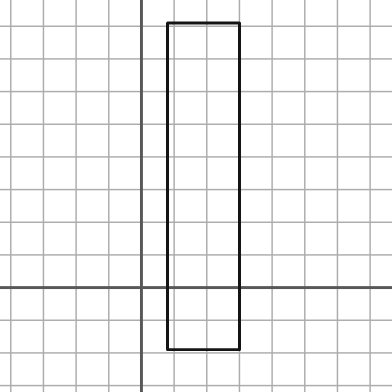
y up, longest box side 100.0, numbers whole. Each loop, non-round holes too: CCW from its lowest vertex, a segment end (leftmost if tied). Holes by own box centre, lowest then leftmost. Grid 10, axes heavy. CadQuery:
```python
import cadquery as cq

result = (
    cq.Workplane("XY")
    .moveTo(8.0, -19.0)
    .lineTo(30.0, -19.0)
    .lineTo(30.0, 81.0)
    .lineTo(8.0, 81.0)
    .close()
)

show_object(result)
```